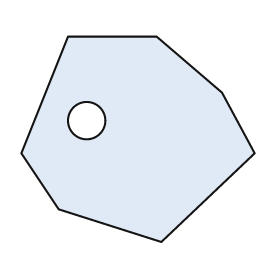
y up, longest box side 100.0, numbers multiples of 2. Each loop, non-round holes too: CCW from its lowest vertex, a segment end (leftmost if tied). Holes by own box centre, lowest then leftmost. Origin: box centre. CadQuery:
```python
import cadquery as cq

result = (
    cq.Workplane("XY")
    .moveTo(10.0, -44.0)
    .lineTo(50.0, -6.0)
    .lineTo(36.0, 20.0)
    .lineTo(8.0, 44.0)
    .lineTo(-30.0, 44.0)
    .lineTo(-50.0, -6.0)
    .lineTo(-34.0, -30.0)
    .close()
    .moveTo(-22.0, 8.0)
    .circle(8.0)
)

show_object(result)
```